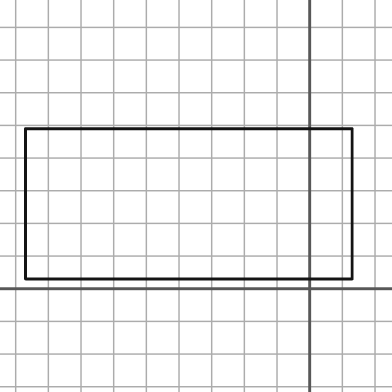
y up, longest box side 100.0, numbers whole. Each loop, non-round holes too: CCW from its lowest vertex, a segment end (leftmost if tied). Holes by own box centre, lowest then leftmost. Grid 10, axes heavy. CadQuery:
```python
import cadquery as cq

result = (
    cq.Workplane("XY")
    .moveTo(-87.0, 3.0)
    .lineTo(13.0, 3.0)
    .lineTo(13.0, 49.0)
    .lineTo(-87.0, 49.0)
    .close()
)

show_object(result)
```